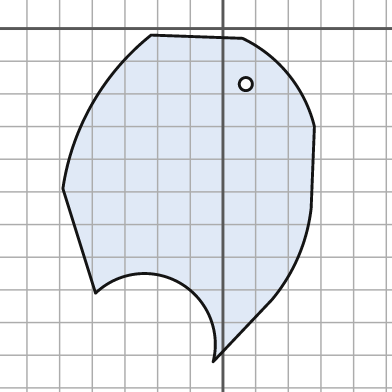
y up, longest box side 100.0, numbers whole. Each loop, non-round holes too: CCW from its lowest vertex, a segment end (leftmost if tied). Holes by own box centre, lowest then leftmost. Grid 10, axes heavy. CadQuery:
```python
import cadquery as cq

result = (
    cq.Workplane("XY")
    .moveTo(-3.0, -102.0)
    .lineTo(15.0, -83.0)
    .threePointArc((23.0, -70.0), (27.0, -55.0))
    .lineTo(28.0, -30.0)
    .threePointArc((20.0, -14.0), (6.0, -3.0))
    .lineTo(-22.0, -2.0)
    .threePointArc((-40.0, -23.0), (-49.0, -49.0))
    .lineTo(-39.0, -81.0)
    .threePointArc((-13.0, -78.0), (-3.0, -102.0))
    .close()
    .moveTo(7.0, -17.0)
    .circle(2.0)
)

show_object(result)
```